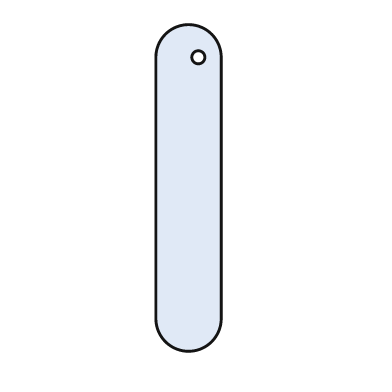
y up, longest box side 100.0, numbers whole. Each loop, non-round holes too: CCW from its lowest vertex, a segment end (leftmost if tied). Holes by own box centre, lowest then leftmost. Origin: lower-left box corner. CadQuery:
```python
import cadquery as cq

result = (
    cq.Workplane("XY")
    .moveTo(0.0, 10.0)
    .threePointArc((10.0, 0.0), (20.0, 10.0))
    .lineTo(20.0, 90.0)
    .threePointArc((10.0, 100.0), (0.0, 90.0))
    .close()
    .moveTo(13.0, 90.0)
    .circle(2.0)
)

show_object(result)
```